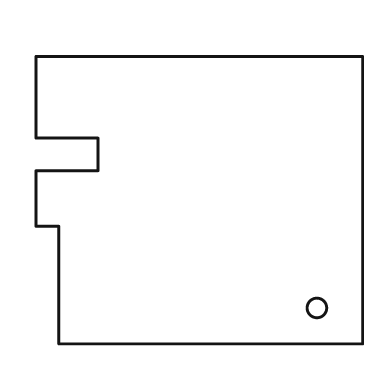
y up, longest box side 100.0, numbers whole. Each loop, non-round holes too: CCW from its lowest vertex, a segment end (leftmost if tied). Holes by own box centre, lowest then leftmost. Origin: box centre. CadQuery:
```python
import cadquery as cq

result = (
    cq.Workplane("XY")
    .moveTo(-43.0, -44.0)
    .lineTo(50.0, -44.0)
    .lineTo(50.0, 44.0)
    .lineTo(-50.0, 44.0)
    .lineTo(-50.0, 19.0)
    .lineTo(-31.0, 19.0)
    .lineTo(-31.0, 9.0)
    .lineTo(-50.0, 9.0)
    .lineTo(-50.0, -8.0)
    .lineTo(-43.0, -8.0)
    .close()
    .moveTo(36.0, -33.0)
    .circle(3.0)
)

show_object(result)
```